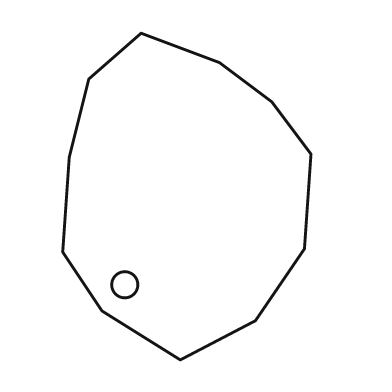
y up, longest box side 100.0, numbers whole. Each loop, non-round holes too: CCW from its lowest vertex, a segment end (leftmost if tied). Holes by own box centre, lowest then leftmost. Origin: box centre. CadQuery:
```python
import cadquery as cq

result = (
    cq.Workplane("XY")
    .moveTo(-2.0, -50.0)
    .lineTo(21.0, -38.0)
    .lineTo(36.0, -16.0)
    .lineTo(38.0, 13.0)
    .lineTo(26.0, 29.0)
    .lineTo(10.0, 41.0)
    .lineTo(-14.0, 50.0)
    .lineTo(-30.0, 36.0)
    .lineTo(-36.0, 12.0)
    .lineTo(-38.0, -17.0)
    .lineTo(-26.0, -35.0)
    .close()
    .moveTo(-19.0, -27.0)
    .circle(4.0)
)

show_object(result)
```